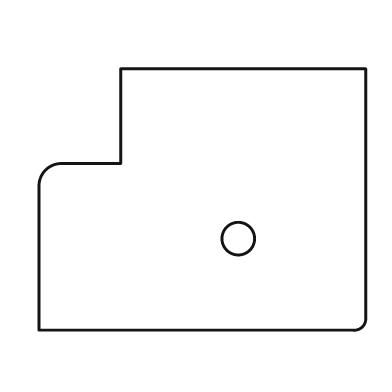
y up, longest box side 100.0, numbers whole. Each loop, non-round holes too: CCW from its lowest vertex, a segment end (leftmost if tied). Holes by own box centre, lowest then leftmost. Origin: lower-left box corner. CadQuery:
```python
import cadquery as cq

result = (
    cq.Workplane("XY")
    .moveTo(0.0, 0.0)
    .lineTo(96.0, 0.0)
    .threePointArc((99.0, 1.0), (100.0, 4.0))
    .lineTo(100.0, 80.0)
    .lineTo(25.0, 80.0)
    .lineTo(25.0, 51.0)
    .lineTo(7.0, 51.0)
    .threePointArc((2.0, 49.0), (0.0, 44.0))
    .close()
    .moveTo(61.0, 28.0)
    .circle(5.0)
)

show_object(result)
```